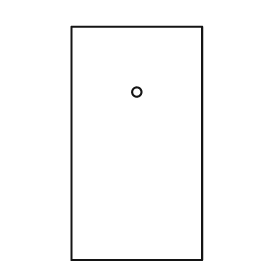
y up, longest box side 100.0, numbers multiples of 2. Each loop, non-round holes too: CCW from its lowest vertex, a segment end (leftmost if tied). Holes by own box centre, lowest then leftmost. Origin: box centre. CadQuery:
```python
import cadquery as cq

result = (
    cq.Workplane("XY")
    .moveTo(-28.0, -50.0)
    .lineTo(28.0, -50.0)
    .lineTo(28.0, 50.0)
    .lineTo(-28.0, 50.0)
    .close()
    .moveTo(0.0, 22.0)
    .circle(2.0)
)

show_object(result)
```